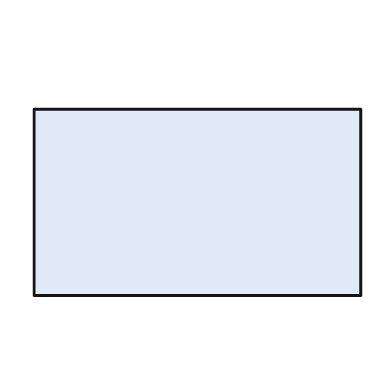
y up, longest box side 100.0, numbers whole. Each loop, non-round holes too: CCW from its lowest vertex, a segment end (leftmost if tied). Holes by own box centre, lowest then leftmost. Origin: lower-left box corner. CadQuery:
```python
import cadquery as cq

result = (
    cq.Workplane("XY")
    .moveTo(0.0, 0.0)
    .lineTo(100.0, 0.0)
    .lineTo(100.0, 57.0)
    .lineTo(0.0, 57.0)
    .close()
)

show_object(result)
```